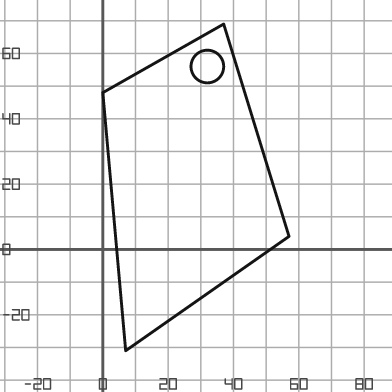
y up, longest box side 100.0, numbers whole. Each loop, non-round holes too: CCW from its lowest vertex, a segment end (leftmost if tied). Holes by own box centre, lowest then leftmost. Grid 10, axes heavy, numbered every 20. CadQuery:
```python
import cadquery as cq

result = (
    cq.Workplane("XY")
    .moveTo(7.0, -31.0)
    .lineTo(57.0, 4.0)
    .lineTo(37.0, 69.0)
    .lineTo(0.0, 48.0)
    .close()
    .moveTo(32.0, 56.0)
    .circle(5.0)
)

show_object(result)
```